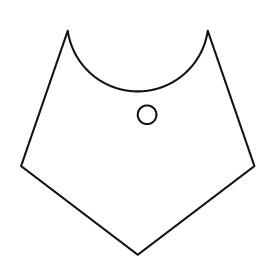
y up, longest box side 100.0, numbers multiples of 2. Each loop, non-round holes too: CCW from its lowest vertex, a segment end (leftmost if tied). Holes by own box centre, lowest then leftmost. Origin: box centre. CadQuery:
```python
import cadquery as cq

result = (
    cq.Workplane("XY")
    .moveTo(0.0, -48.0)
    .lineTo(50.0, -10.0)
    .lineTo(30.0, 48.0)
    .threePointArc((0.0, 22.0), (-30.0, 48.0))
    .lineTo(-50.0, -10.0)
    .close()
    .moveTo(4.0, 12.0)
    .circle(4.0)
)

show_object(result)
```